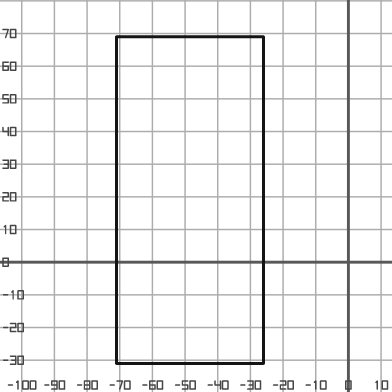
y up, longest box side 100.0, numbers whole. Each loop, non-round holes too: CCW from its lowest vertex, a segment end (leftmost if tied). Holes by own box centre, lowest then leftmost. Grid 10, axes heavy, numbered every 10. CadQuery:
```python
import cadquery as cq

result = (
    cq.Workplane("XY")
    .moveTo(-71.0, -31.0)
    .lineTo(-26.0, -31.0)
    .lineTo(-26.0, 69.0)
    .lineTo(-71.0, 69.0)
    .close()
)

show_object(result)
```